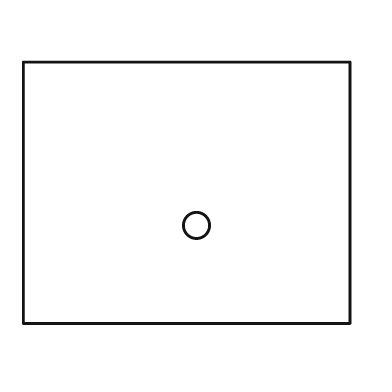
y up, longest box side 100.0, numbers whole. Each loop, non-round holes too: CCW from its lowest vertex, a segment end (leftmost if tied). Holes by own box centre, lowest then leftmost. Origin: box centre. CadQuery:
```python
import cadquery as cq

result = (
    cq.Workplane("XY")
    .moveTo(-50.0, -40.0)
    .lineTo(50.0, -40.0)
    .lineTo(50.0, 40.0)
    .lineTo(-50.0, 40.0)
    .close()
    .moveTo(3.0, -10.0)
    .circle(4.0)
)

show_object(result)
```